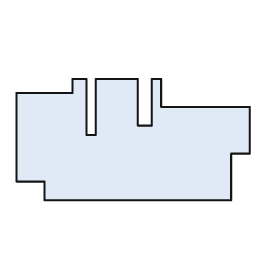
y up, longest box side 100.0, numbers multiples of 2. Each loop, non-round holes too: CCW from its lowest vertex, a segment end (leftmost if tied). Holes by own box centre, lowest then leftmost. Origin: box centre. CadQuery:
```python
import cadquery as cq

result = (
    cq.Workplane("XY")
    .moveTo(-38.0, -26.0)
    .lineTo(42.0, -26.0)
    .lineTo(42.0, -6.0)
    .lineTo(50.0, -6.0)
    .lineTo(50.0, 14.0)
    .lineTo(12.0, 14.0)
    .lineTo(12.0, 26.0)
    .lineTo(8.0, 26.0)
    .lineTo(8.0, 6.0)
    .lineTo(2.0, 6.0)
    .lineTo(2.0, 26.0)
    .lineTo(-16.0, 26.0)
    .lineTo(-16.0, 2.0)
    .lineTo(-20.0, 2.0)
    .lineTo(-20.0, 26.0)
    .lineTo(-26.0, 26.0)
    .lineTo(-26.0, 20.0)
    .lineTo(-50.0, 20.0)
    .lineTo(-50.0, -18.0)
    .lineTo(-38.0, -18.0)
    .close()
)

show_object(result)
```